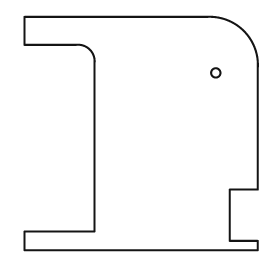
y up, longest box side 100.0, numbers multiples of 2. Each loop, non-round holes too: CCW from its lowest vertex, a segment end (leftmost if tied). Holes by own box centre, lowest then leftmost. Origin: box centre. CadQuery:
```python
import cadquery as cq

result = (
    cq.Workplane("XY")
    .moveTo(-50.0, -50.0)
    .lineTo(50.0, -50.0)
    .lineTo(50.0, -46.0)
    .lineTo(38.0, -46.0)
    .lineTo(38.0, -24.0)
    .lineTo(50.0, -24.0)
    .lineTo(50.0, 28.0)
    .threePointArc((44.0, 44.0), (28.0, 50.0))
    .lineTo(-50.0, 50.0)
    .lineTo(-50.0, 38.0)
    .lineTo(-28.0, 38.0)
    .threePointArc((-22.0, 36.0), (-20.0, 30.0))
    .lineTo(-20.0, -42.0)
    .lineTo(-50.0, -42.0)
    .close()
    .moveTo(32.0, 26.0)
    .circle(2.0)
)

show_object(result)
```